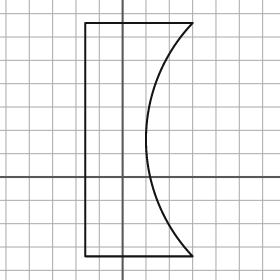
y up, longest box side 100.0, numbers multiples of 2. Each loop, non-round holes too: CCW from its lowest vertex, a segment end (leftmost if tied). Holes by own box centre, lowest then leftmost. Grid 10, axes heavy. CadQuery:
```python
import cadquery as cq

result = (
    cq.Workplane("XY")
    .moveTo(-16.0, -34.0)
    .lineTo(30.0, -34.0)
    .threePointArc((10.0, 16.0), (30.0, 66.0))
    .lineTo(-16.0, 66.0)
    .close()
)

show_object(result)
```